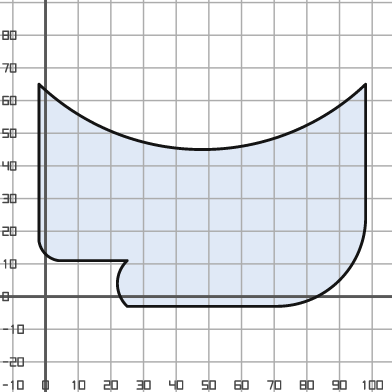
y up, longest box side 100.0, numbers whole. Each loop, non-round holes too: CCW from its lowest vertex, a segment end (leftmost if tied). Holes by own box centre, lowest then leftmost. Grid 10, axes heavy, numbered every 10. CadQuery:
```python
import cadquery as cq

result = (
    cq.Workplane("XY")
    .moveTo(25.0, -3.0)
    .lineTo(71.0, -3.0)
    .threePointArc((90.0, 5.0), (98.0, 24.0))
    .lineTo(98.0, 65.0)
    .threePointArc((48.0, 45.0), (-2.0, 65.0))
    .lineTo(-2.0, 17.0)
    .threePointArc((0.0, 13.0), (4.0, 11.0))
    .lineTo(25.0, 11.0)
    .threePointArc((22.0, 4.0), (25.0, -3.0))
    .close()
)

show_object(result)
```